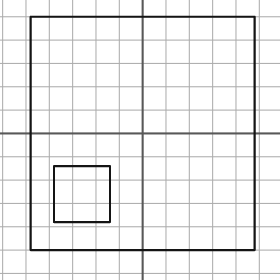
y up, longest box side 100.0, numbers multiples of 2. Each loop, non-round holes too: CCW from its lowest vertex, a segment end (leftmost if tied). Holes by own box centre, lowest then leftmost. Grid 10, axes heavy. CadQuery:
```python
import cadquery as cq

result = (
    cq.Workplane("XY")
    .moveTo(-48.0, -50.0)
    .lineTo(48.0, -50.0)
    .lineTo(48.0, 50.0)
    .lineTo(-48.0, 50.0)
    .close()
    .moveTo(-38.0, -38.0)
    .lineTo(-14.0, -38.0)
    .lineTo(-14.0, -14.0)
    .lineTo(-38.0, -14.0)
    .close()
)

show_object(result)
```